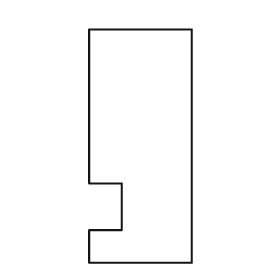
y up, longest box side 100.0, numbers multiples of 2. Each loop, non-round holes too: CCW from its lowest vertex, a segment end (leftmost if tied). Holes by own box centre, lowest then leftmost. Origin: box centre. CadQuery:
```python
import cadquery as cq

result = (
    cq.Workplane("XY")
    .moveTo(-22.0, -50.0)
    .lineTo(22.0, -50.0)
    .lineTo(22.0, 50.0)
    .lineTo(-22.0, 50.0)
    .lineTo(-22.0, -16.0)
    .lineTo(-8.0, -16.0)
    .lineTo(-8.0, -36.0)
    .lineTo(-22.0, -36.0)
    .close()
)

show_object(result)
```